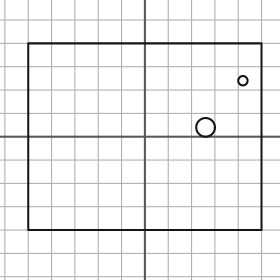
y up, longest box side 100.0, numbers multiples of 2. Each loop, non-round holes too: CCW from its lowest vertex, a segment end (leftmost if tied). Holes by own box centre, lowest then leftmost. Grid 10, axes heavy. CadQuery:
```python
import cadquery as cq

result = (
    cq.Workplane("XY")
    .moveTo(-50.0, -40.0)
    .lineTo(50.0, -40.0)
    .lineTo(50.0, 40.0)
    .lineTo(-50.0, 40.0)
    .close()
    .moveTo(26.0, 4.0)
    .circle(4.0)
    .moveTo(42.0, 24.0)
    .circle(2.0)
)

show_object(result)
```